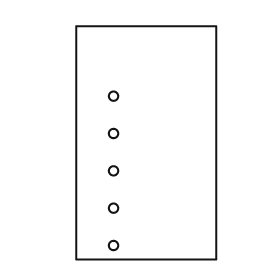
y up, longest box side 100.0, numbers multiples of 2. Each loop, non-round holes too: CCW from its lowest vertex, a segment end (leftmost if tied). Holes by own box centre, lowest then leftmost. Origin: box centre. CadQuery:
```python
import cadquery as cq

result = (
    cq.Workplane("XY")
    .moveTo(-30.0, -50.0)
    .lineTo(30.0, -50.0)
    .lineTo(30.0, 50.0)
    .lineTo(-30.0, 50.0)
    .close()
    .moveTo(-14.0, -44.0)
    .circle(2.0)
    .moveTo(-14.0, -28.0)
    .circle(2.0)
    .moveTo(-14.0, -12.0)
    .circle(2.0)
    .moveTo(-14.0, 4.0)
    .circle(2.0)
    .moveTo(-14.0, 20.0)
    .circle(2.0)
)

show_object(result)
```